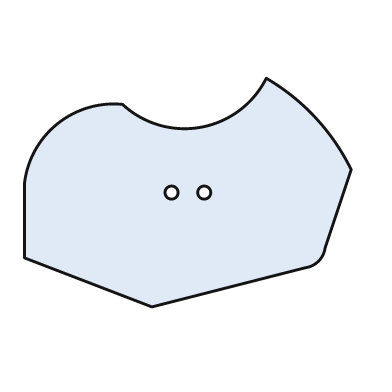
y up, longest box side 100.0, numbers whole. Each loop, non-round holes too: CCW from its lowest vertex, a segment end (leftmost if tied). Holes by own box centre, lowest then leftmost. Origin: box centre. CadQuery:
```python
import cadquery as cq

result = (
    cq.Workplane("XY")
    .moveTo(-11.0, -35.0)
    .lineTo(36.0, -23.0)
    .threePointArc((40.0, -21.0), (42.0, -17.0))
    .lineTo(50.0, 7.0)
    .threePointArc((39.0, 23.0), (24.0, 35.0))
    .threePointArc((4.0, 20.0), (-20.0, 27.0))
    .threePointArc((-40.0, 21.0), (-50.0, 3.0))
    .lineTo(-50.0, -20.0)
    .close()
    .moveTo(-5.0, 0.0)
    .circle(2.0)
    .moveTo(5.0, 0.0)
    .circle(2.0)
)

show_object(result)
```